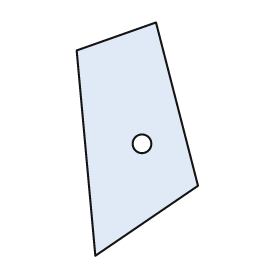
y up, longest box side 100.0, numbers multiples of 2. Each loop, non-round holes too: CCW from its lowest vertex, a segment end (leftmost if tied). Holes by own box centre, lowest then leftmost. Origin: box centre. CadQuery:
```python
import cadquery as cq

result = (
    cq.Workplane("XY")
    .moveTo(-18.0, -50.0)
    .lineTo(26.0, -20.0)
    .lineTo(8.0, 50.0)
    .lineTo(-26.0, 38.0)
    .close()
    .moveTo(2.0, -2.0)
    .circle(4.0)
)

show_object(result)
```